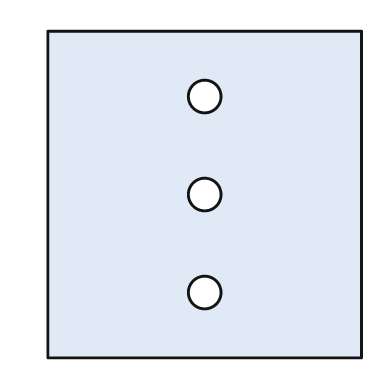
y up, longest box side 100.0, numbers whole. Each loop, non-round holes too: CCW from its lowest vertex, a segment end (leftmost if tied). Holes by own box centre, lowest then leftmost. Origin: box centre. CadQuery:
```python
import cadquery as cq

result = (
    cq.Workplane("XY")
    .moveTo(-48.0, -50.0)
    .lineTo(48.0, -50.0)
    .lineTo(48.0, 50.0)
    .lineTo(-48.0, 50.0)
    .close()
    .moveTo(0.0, -30.0)
    .circle(5.0)
    .moveTo(0.0, 0.0)
    .circle(5.0)
    .moveTo(0.0, 30.0)
    .circle(5.0)
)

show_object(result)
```